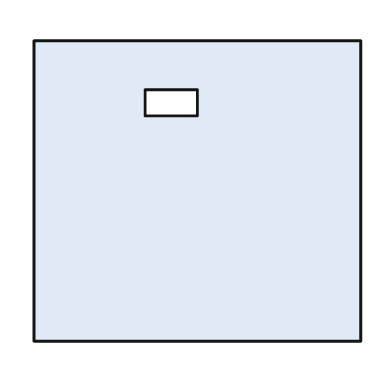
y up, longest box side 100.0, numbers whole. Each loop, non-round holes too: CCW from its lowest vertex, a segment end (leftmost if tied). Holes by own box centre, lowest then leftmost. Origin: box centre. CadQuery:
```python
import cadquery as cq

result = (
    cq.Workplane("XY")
    .moveTo(-50.0, -46.0)
    .lineTo(50.0, -46.0)
    .lineTo(50.0, 46.0)
    .lineTo(-50.0, 46.0)
    .close()
    .moveTo(-16.0, 23.0)
    .lineTo(0.0, 23.0)
    .lineTo(0.0, 31.0)
    .lineTo(-16.0, 31.0)
    .close()
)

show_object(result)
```